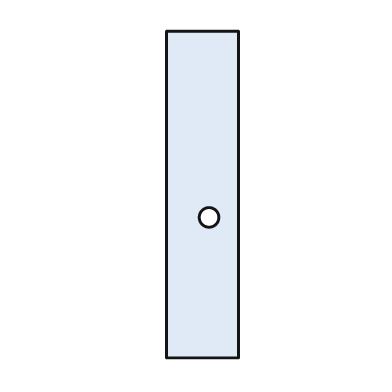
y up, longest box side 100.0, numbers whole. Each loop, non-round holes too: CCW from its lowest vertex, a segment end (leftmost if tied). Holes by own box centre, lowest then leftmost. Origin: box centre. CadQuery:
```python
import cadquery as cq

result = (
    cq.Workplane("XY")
    .moveTo(-11.0, -50.0)
    .lineTo(11.0, -50.0)
    .lineTo(11.0, 50.0)
    .lineTo(-11.0, 50.0)
    .close()
    .moveTo(2.0, -7.0)
    .circle(3.0)
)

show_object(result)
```